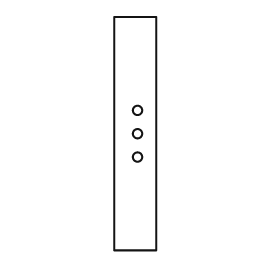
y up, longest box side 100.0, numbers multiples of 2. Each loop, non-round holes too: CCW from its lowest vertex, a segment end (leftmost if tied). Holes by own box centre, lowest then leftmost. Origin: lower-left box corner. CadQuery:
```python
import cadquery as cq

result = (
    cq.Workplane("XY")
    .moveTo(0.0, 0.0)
    .lineTo(18.0, 0.0)
    .lineTo(18.0, 100.0)
    .lineTo(0.0, 100.0)
    .close()
    .moveTo(10.0, 40.0)
    .circle(2.0)
    .moveTo(10.0, 50.0)
    .circle(2.0)
    .moveTo(10.0, 60.0)
    .circle(2.0)
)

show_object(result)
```